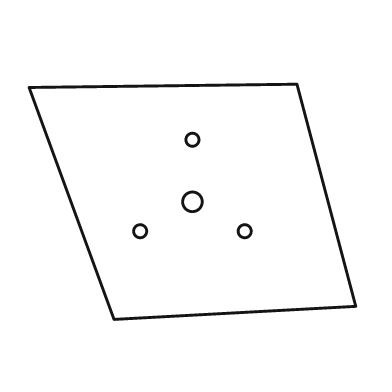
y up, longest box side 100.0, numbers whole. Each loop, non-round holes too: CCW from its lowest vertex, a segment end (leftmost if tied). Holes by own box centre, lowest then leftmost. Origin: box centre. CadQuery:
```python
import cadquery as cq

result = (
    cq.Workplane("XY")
    .moveTo(-24.0, -36.0)
    .lineTo(50.0, -32.0)
    .lineTo(32.0, 36.0)
    .lineTo(-50.0, 35.0)
    .close()
    .moveTo(-16.0, -9.0)
    .circle(2.0)
    .moveTo(16.0, -9.0)
    .circle(2.0)
    .moveTo(0.0, 0.0)
    .circle(3.0)
    .moveTo(0.0, 19.0)
    .circle(2.0)
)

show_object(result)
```